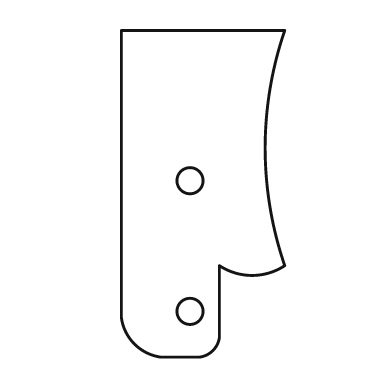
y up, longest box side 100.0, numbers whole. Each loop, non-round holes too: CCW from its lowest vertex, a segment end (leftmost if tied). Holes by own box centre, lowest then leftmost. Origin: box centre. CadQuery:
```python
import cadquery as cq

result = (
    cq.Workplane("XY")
    .moveTo(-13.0, -50.0)
    .lineTo(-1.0, -50.0)
    .threePointArc((3.0, -48.0), (5.0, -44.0))
    .lineTo(5.0, -22.0)
    .threePointArc((15.0, -25.0), (25.0, -22.0))
    .threePointArc((19.0, 14.0), (25.0, 50.0))
    .lineTo(-25.0, 50.0)
    .lineTo(-25.0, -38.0)
    .threePointArc((-21.0, -46.0), (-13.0, -50.0))
    .close()
    .moveTo(-4.0, -36.0)
    .circle(4.0)
    .moveTo(-4.0, 4.0)
    .circle(4.0)
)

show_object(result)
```